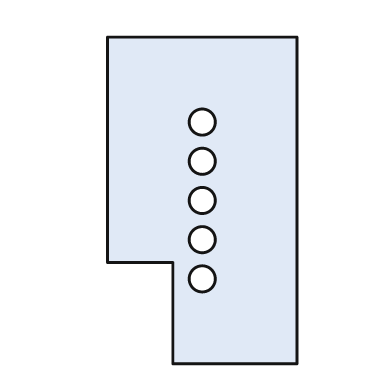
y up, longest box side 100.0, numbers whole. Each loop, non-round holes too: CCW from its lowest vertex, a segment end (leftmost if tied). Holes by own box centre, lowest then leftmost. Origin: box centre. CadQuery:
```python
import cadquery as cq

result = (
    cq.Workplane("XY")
    .moveTo(-9.0, -50.0)
    .lineTo(29.0, -50.0)
    .lineTo(29.0, 50.0)
    .lineTo(-29.0, 50.0)
    .lineTo(-29.0, -19.0)
    .lineTo(-9.0, -19.0)
    .close()
    .moveTo(0.0, -24.0)
    .circle(4.0)
    .moveTo(0.0, -12.0)
    .circle(4.0)
    .moveTo(0.0, 0.0)
    .circle(4.0)
    .moveTo(0.0, 12.0)
    .circle(4.0)
    .moveTo(0.0, 24.0)
    .circle(4.0)
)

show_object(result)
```